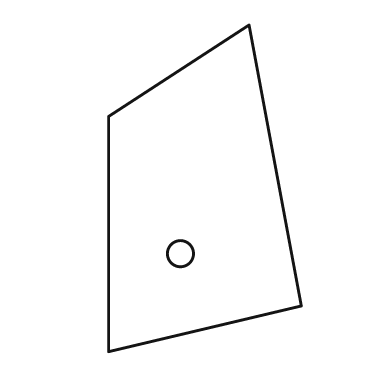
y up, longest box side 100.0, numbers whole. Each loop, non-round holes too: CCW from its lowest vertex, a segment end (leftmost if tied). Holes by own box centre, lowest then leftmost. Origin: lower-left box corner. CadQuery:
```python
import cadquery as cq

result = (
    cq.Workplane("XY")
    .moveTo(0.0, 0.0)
    .lineTo(59.0, 14.0)
    .lineTo(43.0, 100.0)
    .lineTo(0.0, 72.0)
    .close()
    .moveTo(22.0, 30.0)
    .circle(4.0)
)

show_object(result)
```